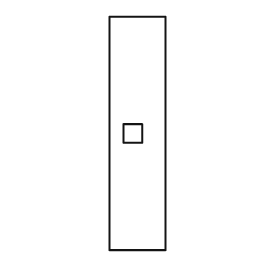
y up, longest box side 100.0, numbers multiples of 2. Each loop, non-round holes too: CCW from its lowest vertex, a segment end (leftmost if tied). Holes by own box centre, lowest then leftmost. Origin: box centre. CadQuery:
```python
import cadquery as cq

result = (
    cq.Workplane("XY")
    .moveTo(-12.0, -50.0)
    .lineTo(12.0, -50.0)
    .lineTo(12.0, 50.0)
    .lineTo(-12.0, 50.0)
    .close()
    .moveTo(-6.0, -4.0)
    .lineTo(2.0, -4.0)
    .lineTo(2.0, 4.0)
    .lineTo(-6.0, 4.0)
    .close()
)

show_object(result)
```